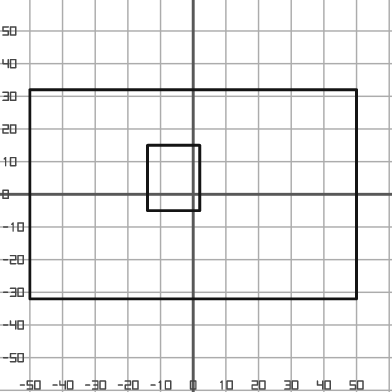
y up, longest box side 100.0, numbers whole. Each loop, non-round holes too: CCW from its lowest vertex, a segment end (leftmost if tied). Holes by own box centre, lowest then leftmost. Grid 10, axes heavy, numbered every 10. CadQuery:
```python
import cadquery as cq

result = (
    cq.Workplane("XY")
    .moveTo(-50.0, -32.0)
    .lineTo(50.0, -32.0)
    .lineTo(50.0, 32.0)
    .lineTo(-50.0, 32.0)
    .close()
    .moveTo(-14.0, -5.0)
    .lineTo(2.0, -5.0)
    .lineTo(2.0, 15.0)
    .lineTo(-14.0, 15.0)
    .close()
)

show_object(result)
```